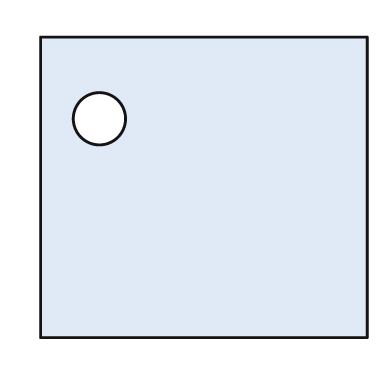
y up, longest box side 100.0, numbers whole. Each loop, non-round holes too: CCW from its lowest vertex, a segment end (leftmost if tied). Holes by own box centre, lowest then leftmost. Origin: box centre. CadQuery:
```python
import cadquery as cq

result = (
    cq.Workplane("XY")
    .moveTo(-50.0, -46.0)
    .lineTo(50.0, -46.0)
    .lineTo(50.0, 46.0)
    .lineTo(-50.0, 46.0)
    .close()
    .moveTo(-32.0, 21.0)
    .circle(8.0)
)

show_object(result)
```